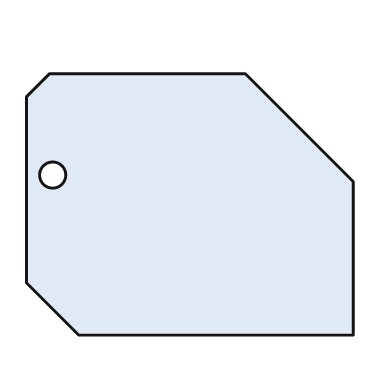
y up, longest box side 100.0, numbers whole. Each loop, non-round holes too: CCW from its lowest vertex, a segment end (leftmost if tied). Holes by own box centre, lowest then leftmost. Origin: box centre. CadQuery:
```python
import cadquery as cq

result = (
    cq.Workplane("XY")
    .moveTo(-34.0, -40.0)
    .lineTo(50.0, -40.0)
    .lineTo(50.0, 7.0)
    .lineTo(17.0, 40.0)
    .lineTo(-43.0, 40.0)
    .lineTo(-50.0, 33.0)
    .lineTo(-50.0, -24.0)
    .close()
    .moveTo(-42.0, 9.0)
    .circle(4.0)
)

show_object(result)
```